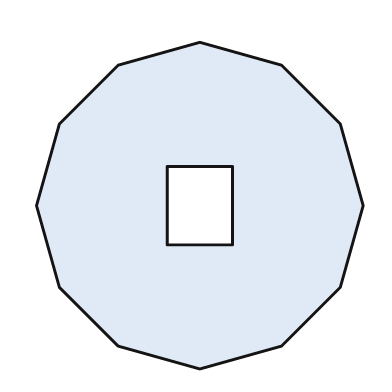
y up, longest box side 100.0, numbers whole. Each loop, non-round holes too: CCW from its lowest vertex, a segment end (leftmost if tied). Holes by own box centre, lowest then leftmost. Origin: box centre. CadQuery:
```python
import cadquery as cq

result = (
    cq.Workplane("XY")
    .moveTo(0.0, -50.0)
    .lineTo(25.0, -43.0)
    .lineTo(43.0, -25.0)
    .lineTo(50.0, 0.0)
    .lineTo(43.0, 25.0)
    .lineTo(25.0, 43.0)
    .lineTo(0.0, 50.0)
    .lineTo(-25.0, 43.0)
    .lineTo(-43.0, 25.0)
    .lineTo(-50.0, 0.0)
    .lineTo(-43.0, -25.0)
    .lineTo(-25.0, -43.0)
    .close()
    .moveTo(-10.0, -12.0)
    .lineTo(10.0, -12.0)
    .lineTo(10.0, 12.0)
    .lineTo(-10.0, 12.0)
    .close()
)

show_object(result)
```